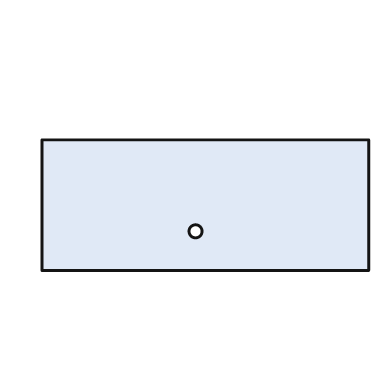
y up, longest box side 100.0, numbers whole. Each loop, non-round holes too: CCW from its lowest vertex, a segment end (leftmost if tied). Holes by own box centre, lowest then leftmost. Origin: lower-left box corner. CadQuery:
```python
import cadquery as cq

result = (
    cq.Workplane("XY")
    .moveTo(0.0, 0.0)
    .lineTo(100.0, 0.0)
    .lineTo(100.0, 40.0)
    .lineTo(0.0, 40.0)
    .close()
    .moveTo(47.0, 12.0)
    .circle(2.0)
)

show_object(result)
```